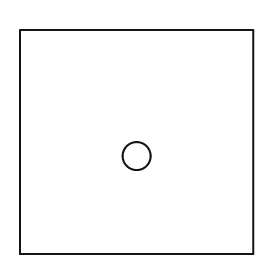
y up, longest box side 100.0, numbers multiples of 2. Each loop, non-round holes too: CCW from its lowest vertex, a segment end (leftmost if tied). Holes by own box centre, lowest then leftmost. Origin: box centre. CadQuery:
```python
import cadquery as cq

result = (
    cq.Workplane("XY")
    .moveTo(-50.0, -48.0)
    .lineTo(50.0, -48.0)
    .lineTo(50.0, 48.0)
    .lineTo(-50.0, 48.0)
    .close()
    .moveTo(0.0, -6.0)
    .circle(6.0)
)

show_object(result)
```